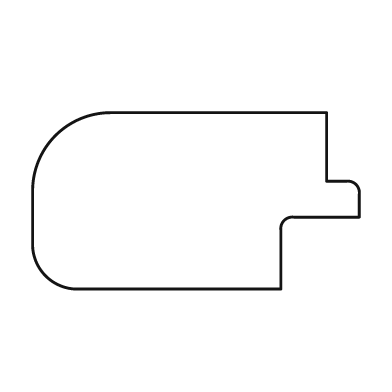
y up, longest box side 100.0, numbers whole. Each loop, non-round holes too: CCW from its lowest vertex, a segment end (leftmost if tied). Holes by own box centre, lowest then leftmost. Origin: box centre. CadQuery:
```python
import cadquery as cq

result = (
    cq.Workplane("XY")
    .moveTo(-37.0, -27.0)
    .lineTo(26.0, -27.0)
    .lineTo(26.0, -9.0)
    .threePointArc((27.0, -6.0), (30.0, -5.0))
    .lineTo(50.0, -5.0)
    .lineTo(50.0, 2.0)
    .threePointArc((49.0, 5.0), (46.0, 6.0))
    .lineTo(40.0, 6.0)
    .lineTo(40.0, 27.0)
    .lineTo(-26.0, 27.0)
    .threePointArc((-43.0, 20.0), (-50.0, 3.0))
    .lineTo(-50.0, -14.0)
    .threePointArc((-46.0, -23.0), (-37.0, -27.0))
    .close()
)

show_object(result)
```